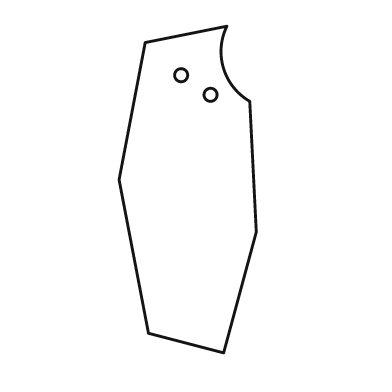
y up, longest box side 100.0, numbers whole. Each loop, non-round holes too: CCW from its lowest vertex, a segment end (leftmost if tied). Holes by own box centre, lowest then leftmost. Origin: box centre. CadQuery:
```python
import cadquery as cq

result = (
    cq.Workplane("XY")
    .moveTo(11.0, -50.0)
    .lineTo(21.0, -13.0)
    .lineTo(19.0, 27.0)
    .threePointArc((11.0, 37.0), (12.0, 50.0))
    .lineTo(-13.0, 45.0)
    .lineTo(-21.0, 3.0)
    .lineTo(-12.0, -44.0)
    .close()
    .moveTo(7.0, 29.0)
    .circle(2.0)
    .moveTo(-2.0, 35.0)
    .circle(2.0)
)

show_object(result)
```